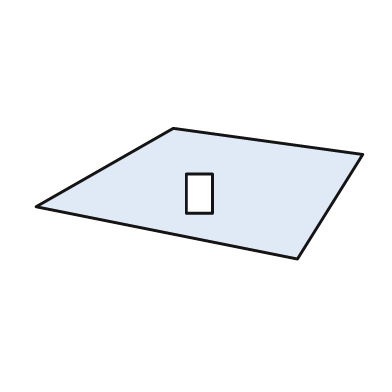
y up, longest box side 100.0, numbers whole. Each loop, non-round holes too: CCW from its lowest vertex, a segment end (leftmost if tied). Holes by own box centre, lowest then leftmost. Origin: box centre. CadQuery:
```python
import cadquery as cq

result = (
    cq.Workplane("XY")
    .moveTo(30.0, -20.0)
    .lineTo(50.0, 12.0)
    .lineTo(-8.0, 20.0)
    .lineTo(-50.0, -4.0)
    .close()
    .moveTo(-4.0, -6.0)
    .lineTo(4.0, -6.0)
    .lineTo(4.0, 6.0)
    .lineTo(-4.0, 6.0)
    .close()
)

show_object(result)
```